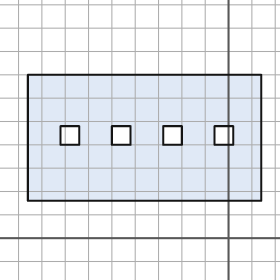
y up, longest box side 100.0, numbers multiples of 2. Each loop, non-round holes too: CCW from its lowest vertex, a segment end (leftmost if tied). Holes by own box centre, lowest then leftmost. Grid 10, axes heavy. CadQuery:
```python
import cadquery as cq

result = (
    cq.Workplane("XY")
    .moveTo(-86.0, 16.0)
    .lineTo(14.0, 16.0)
    .lineTo(14.0, 70.0)
    .lineTo(-86.0, 70.0)
    .close()
    .moveTo(-72.0, 40.0)
    .lineTo(-64.0, 40.0)
    .lineTo(-64.0, 48.0)
    .lineTo(-72.0, 48.0)
    .close()
    .moveTo(-50.0, 40.0)
    .lineTo(-42.0, 40.0)
    .lineTo(-42.0, 48.0)
    .lineTo(-50.0, 48.0)
    .close()
    .moveTo(-28.0, 40.0)
    .lineTo(-20.0, 40.0)
    .lineTo(-20.0, 48.0)
    .lineTo(-28.0, 48.0)
    .close()
    .moveTo(-6.0, 40.0)
    .lineTo(2.0, 40.0)
    .lineTo(2.0, 48.0)
    .lineTo(-6.0, 48.0)
    .close()
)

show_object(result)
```